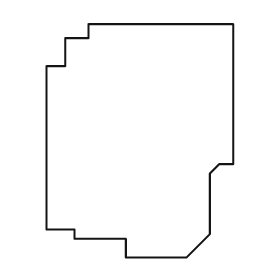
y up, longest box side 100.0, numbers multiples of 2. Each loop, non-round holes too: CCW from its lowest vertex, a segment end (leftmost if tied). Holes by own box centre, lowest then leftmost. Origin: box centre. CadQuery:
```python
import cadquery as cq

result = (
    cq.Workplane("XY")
    .moveTo(-6.0, -50.0)
    .lineTo(20.0, -50.0)
    .lineTo(30.0, -40.0)
    .lineTo(30.0, -14.0)
    .lineTo(34.0, -10.0)
    .lineTo(40.0, -10.0)
    .lineTo(40.0, 50.0)
    .lineTo(-22.0, 50.0)
    .lineTo(-22.0, 44.0)
    .lineTo(-32.0, 44.0)
    .lineTo(-32.0, 32.0)
    .lineTo(-40.0, 32.0)
    .lineTo(-40.0, -38.0)
    .lineTo(-28.0, -38.0)
    .lineTo(-28.0, -42.0)
    .lineTo(-6.0, -42.0)
    .close()
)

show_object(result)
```